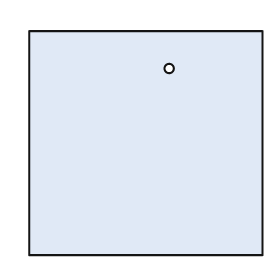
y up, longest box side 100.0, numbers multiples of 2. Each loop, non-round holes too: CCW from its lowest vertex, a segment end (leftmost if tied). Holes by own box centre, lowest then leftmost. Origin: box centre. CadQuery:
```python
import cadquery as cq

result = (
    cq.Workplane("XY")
    .moveTo(-50.0, -48.0)
    .lineTo(50.0, -48.0)
    .lineTo(50.0, 48.0)
    .lineTo(-50.0, 48.0)
    .close()
    .moveTo(10.0, 32.0)
    .circle(2.0)
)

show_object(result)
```